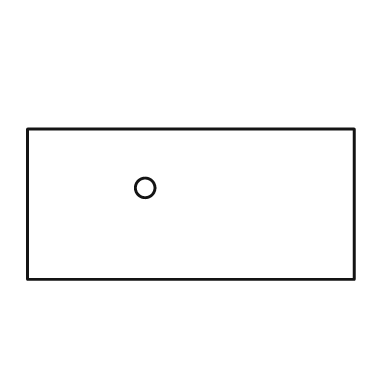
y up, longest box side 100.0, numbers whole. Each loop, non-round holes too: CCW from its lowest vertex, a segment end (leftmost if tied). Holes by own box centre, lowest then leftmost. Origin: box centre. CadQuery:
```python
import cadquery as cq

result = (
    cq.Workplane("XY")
    .moveTo(-50.0, -23.0)
    .lineTo(50.0, -23.0)
    .lineTo(50.0, 23.0)
    .lineTo(-50.0, 23.0)
    .close()
    .moveTo(-14.0, 5.0)
    .circle(3.0)
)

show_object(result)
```